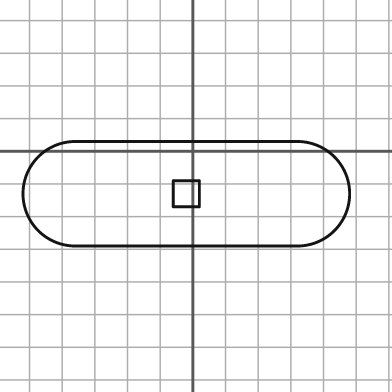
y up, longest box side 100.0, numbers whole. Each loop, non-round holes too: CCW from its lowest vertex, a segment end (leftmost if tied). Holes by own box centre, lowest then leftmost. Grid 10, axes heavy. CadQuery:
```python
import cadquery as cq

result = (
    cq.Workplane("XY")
    .moveTo(-36.0, -29.0)
    .lineTo(32.0, -29.0)
    .threePointArc((48.0, -13.0), (32.0, 3.0))
    .lineTo(-36.0, 3.0)
    .threePointArc((-52.0, -13.0), (-36.0, -29.0))
    .close()
    .moveTo(-6.0, -17.0)
    .lineTo(2.0, -17.0)
    .lineTo(2.0, -9.0)
    .lineTo(-6.0, -9.0)
    .close()
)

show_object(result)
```